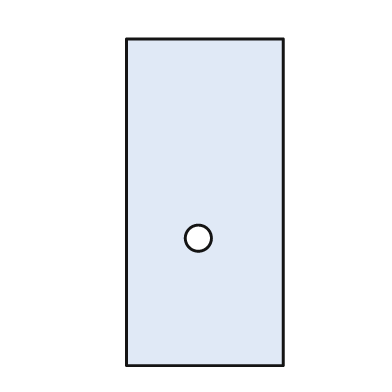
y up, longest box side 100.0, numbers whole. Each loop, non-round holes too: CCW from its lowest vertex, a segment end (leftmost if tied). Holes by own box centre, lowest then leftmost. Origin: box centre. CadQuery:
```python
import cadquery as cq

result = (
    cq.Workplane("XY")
    .moveTo(-24.0, -50.0)
    .lineTo(24.0, -50.0)
    .lineTo(24.0, 50.0)
    .lineTo(-24.0, 50.0)
    .close()
    .moveTo(-2.0, -11.0)
    .circle(4.0)
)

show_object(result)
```